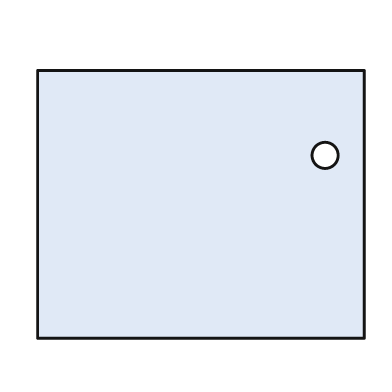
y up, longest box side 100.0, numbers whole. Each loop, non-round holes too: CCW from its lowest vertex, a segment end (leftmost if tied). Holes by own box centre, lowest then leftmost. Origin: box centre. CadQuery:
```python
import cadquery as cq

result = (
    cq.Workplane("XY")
    .moveTo(-50.0, -41.0)
    .lineTo(50.0, -41.0)
    .lineTo(50.0, 41.0)
    .lineTo(-50.0, 41.0)
    .close()
    .moveTo(38.0, 15.0)
    .circle(4.0)
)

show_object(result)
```